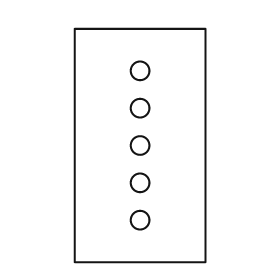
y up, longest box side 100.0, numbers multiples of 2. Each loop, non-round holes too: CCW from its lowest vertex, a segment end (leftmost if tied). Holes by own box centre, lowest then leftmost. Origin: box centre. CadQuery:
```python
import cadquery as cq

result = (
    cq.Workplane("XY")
    .moveTo(-28.0, -50.0)
    .lineTo(28.0, -50.0)
    .lineTo(28.0, 50.0)
    .lineTo(-28.0, 50.0)
    .close()
    .moveTo(0.0, -32.0)
    .circle(4.0)
    .moveTo(0.0, -16.0)
    .circle(4.0)
    .moveTo(0.0, 0.0)
    .circle(4.0)
    .moveTo(0.0, 16.0)
    .circle(4.0)
    .moveTo(0.0, 32.0)
    .circle(4.0)
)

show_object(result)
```